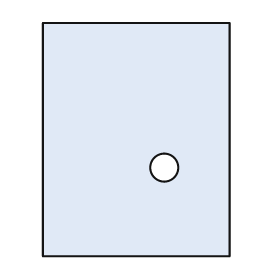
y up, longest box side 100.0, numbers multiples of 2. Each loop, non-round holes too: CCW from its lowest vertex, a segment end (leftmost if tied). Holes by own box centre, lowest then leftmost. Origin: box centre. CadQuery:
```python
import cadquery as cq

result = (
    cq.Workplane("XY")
    .moveTo(-40.0, -50.0)
    .lineTo(40.0, -50.0)
    .lineTo(40.0, 50.0)
    .lineTo(-40.0, 50.0)
    .close()
    .moveTo(12.0, -12.0)
    .circle(6.0)
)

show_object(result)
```